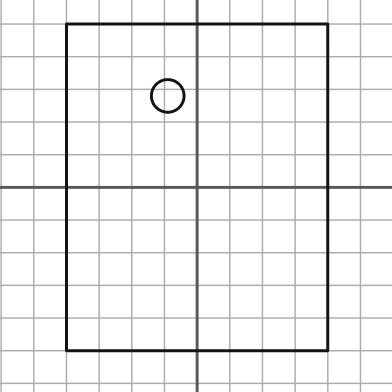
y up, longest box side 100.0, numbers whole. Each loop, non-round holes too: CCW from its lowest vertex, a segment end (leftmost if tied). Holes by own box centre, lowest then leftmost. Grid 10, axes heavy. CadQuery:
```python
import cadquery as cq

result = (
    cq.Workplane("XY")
    .moveTo(-40.0, -50.0)
    .lineTo(40.0, -50.0)
    .lineTo(40.0, 50.0)
    .lineTo(-40.0, 50.0)
    .close()
    .moveTo(-9.0, 28.0)
    .circle(5.0)
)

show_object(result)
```